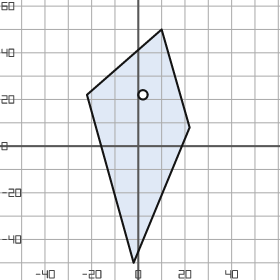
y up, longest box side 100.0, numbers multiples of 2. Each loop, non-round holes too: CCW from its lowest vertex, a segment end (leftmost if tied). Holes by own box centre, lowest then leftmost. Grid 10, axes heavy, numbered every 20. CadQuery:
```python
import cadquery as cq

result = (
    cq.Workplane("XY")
    .moveTo(-2.0, -50.0)
    .lineTo(22.0, 8.0)
    .lineTo(10.0, 50.0)
    .lineTo(-22.0, 22.0)
    .close()
    .moveTo(2.0, 22.0)
    .circle(2.0)
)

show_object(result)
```